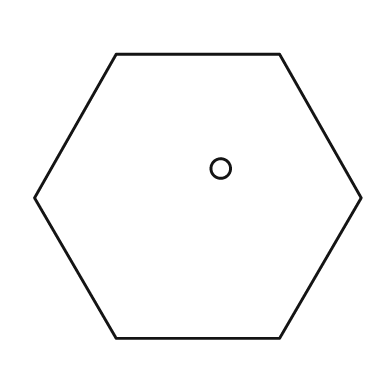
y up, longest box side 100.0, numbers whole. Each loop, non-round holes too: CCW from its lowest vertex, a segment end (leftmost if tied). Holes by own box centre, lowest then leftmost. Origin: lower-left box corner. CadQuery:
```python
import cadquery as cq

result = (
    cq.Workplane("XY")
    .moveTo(25.0, 0.0)
    .lineTo(75.0, 0.0)
    .lineTo(100.0, 43.0)
    .lineTo(75.0, 87.0)
    .lineTo(25.0, 87.0)
    .lineTo(0.0, 43.0)
    .close()
    .moveTo(57.0, 52.0)
    .circle(3.0)
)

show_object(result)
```